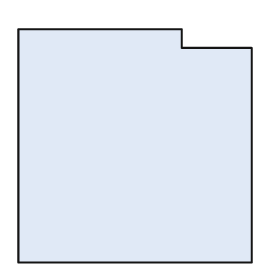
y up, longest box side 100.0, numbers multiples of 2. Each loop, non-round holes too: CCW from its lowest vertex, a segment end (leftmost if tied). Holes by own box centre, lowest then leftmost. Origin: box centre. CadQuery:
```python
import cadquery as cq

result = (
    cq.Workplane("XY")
    .moveTo(-50.0, -50.0)
    .lineTo(50.0, -50.0)
    .lineTo(50.0, 42.0)
    .lineTo(20.0, 42.0)
    .lineTo(20.0, 50.0)
    .lineTo(-50.0, 50.0)
    .close()
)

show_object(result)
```